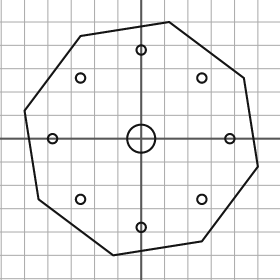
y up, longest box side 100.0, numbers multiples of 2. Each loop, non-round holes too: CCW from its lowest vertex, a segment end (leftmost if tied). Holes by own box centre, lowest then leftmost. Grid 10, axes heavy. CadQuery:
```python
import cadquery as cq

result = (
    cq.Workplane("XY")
    .moveTo(-12.0, -50.0)
    .lineTo(26.0, -44.0)
    .lineTo(50.0, -12.0)
    .lineTo(44.0, 26.0)
    .lineTo(12.0, 50.0)
    .lineTo(-26.0, 44.0)
    .lineTo(-50.0, 12.0)
    .lineTo(-44.0, -26.0)
    .close()
    .moveTo(0.0, -38.0)
    .circle(2.0)
    .moveTo(-26.0, -26.0)
    .circle(2.0)
    .moveTo(26.0, -26.0)
    .circle(2.0)
    .moveTo(-38.0, 0.0)
    .circle(2.0)
    .moveTo(0.0, 0.0)
    .circle(6.0)
    .moveTo(38.0, 0.0)
    .circle(2.0)
    .moveTo(-26.0, 26.0)
    .circle(2.0)
    .moveTo(26.0, 26.0)
    .circle(2.0)
    .moveTo(0.0, 38.0)
    .circle(2.0)
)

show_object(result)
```